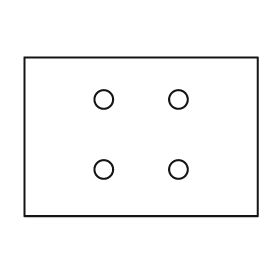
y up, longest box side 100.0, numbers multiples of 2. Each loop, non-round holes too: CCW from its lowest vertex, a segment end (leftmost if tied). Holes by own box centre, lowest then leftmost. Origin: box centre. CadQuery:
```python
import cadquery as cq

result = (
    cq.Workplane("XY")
    .moveTo(-50.0, -34.0)
    .lineTo(50.0, -34.0)
    .lineTo(50.0, 34.0)
    .lineTo(-50.0, 34.0)
    .close()
    .moveTo(-16.0, -14.0)
    .circle(4.0)
    .moveTo(16.0, -14.0)
    .circle(4.0)
    .moveTo(-16.0, 16.0)
    .circle(4.0)
    .moveTo(16.0, 16.0)
    .circle(4.0)
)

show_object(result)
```